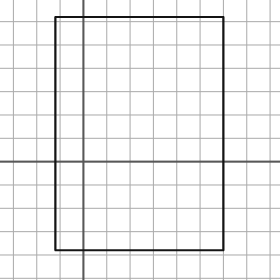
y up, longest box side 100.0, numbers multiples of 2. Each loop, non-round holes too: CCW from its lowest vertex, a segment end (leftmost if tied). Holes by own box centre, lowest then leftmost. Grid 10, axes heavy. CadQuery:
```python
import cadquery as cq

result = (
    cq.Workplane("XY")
    .moveTo(-12.0, -38.0)
    .lineTo(60.0, -38.0)
    .lineTo(60.0, 62.0)
    .lineTo(-12.0, 62.0)
    .close()
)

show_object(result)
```